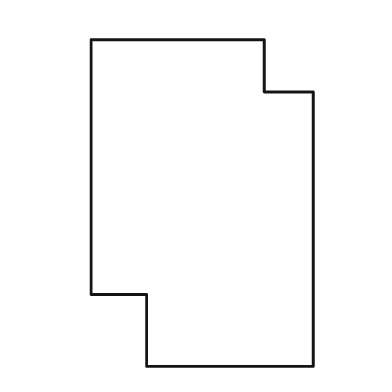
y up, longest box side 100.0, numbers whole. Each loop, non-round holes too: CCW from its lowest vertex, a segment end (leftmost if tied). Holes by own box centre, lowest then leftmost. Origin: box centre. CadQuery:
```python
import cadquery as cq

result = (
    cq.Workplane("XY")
    .moveTo(-17.0, -50.0)
    .lineTo(34.0, -50.0)
    .lineTo(34.0, 34.0)
    .lineTo(19.0, 34.0)
    .lineTo(19.0, 50.0)
    .lineTo(-34.0, 50.0)
    .lineTo(-34.0, -28.0)
    .lineTo(-17.0, -28.0)
    .close()
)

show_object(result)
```